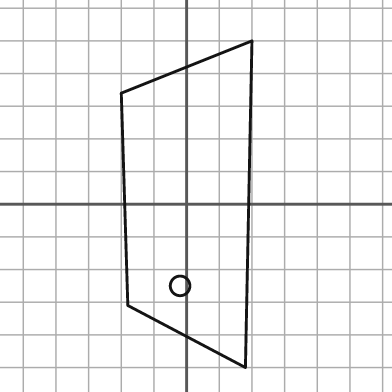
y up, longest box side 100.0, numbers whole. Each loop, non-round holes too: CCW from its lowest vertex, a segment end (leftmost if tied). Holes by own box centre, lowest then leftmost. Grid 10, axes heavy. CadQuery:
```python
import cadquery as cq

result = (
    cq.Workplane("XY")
    .moveTo(18.0, -50.0)
    .lineTo(20.0, 50.0)
    .lineTo(-20.0, 34.0)
    .lineTo(-18.0, -31.0)
    .close()
    .moveTo(-2.0, -25.0)
    .circle(3.0)
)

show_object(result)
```